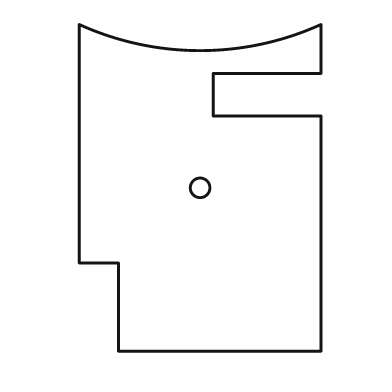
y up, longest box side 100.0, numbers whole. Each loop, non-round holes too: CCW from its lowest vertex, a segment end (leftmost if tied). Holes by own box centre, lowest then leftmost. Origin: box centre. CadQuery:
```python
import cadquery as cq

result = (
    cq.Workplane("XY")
    .moveTo(-25.0, -50.0)
    .lineTo(37.0, -50.0)
    .lineTo(37.0, 22.0)
    .lineTo(4.0, 22.0)
    .lineTo(4.0, 35.0)
    .lineTo(37.0, 35.0)
    .lineTo(37.0, 50.0)
    .threePointArc((0.0, 42.0), (-37.0, 50.0))
    .lineTo(-37.0, -23.0)
    .lineTo(-25.0, -23.0)
    .close()
    .moveTo(0.0, 0.0)
    .circle(3.0)
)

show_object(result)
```